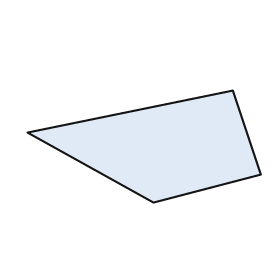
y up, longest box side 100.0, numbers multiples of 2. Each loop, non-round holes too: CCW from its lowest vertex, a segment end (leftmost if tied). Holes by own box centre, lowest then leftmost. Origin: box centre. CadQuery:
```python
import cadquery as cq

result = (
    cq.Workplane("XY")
    .moveTo(4.0, -24.0)
    .lineTo(50.0, -12.0)
    .lineTo(38.0, 24.0)
    .lineTo(-50.0, 6.0)
    .close()
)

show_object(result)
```